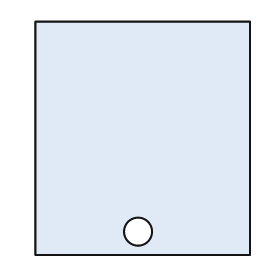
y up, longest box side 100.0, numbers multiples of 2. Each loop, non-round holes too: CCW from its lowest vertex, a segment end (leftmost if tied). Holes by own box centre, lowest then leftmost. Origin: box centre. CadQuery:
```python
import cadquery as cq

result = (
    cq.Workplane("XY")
    .moveTo(-46.0, -50.0)
    .lineTo(46.0, -50.0)
    .lineTo(46.0, 50.0)
    .lineTo(-46.0, 50.0)
    .close()
    .moveTo(-2.0, -40.0)
    .circle(6.0)
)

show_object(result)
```